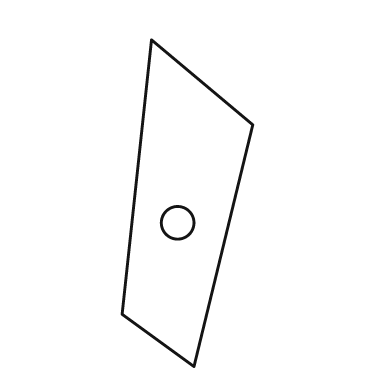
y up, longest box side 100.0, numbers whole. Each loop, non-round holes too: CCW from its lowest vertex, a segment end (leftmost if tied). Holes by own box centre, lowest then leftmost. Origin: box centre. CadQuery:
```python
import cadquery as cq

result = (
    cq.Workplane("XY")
    .moveTo(2.0, -50.0)
    .lineTo(20.0, 24.0)
    .lineTo(-11.0, 50.0)
    .lineTo(-20.0, -34.0)
    .close()
    .moveTo(-3.0, -6.0)
    .circle(5.0)
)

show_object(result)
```